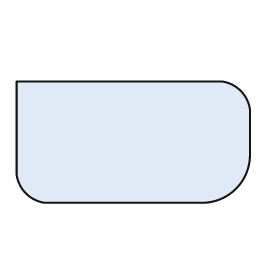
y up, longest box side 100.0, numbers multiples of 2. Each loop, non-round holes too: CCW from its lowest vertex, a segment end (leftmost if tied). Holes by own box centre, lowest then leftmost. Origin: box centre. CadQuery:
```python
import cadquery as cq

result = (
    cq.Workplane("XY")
    .moveTo(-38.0, -26.0)
    .lineTo(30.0, -26.0)
    .threePointArc((44.0, -20.0), (50.0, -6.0))
    .lineTo(50.0, 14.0)
    .threePointArc((46.0, 22.0), (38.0, 26.0))
    .lineTo(-50.0, 26.0)
    .lineTo(-50.0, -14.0)
    .threePointArc((-46.0, -22.0), (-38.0, -26.0))
    .close()
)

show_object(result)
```